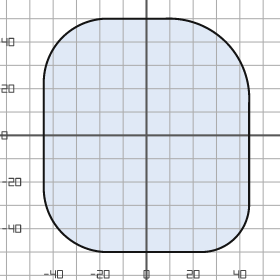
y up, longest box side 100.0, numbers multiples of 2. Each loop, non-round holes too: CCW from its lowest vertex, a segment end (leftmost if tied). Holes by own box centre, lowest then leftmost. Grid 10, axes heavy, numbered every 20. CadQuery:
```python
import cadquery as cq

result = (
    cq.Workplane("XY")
    .moveTo(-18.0, -50.0)
    .lineTo(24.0, -50.0)
    .threePointArc((38.0, -44.0), (44.0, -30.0))
    .lineTo(44.0, 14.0)
    .threePointArc((34.0, 40.0), (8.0, 50.0))
    .lineTo(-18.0, 50.0)
    .threePointArc((-36.0, 42.0), (-44.0, 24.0))
    .lineTo(-44.0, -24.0)
    .threePointArc((-36.0, -42.0), (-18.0, -50.0))
    .close()
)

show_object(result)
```